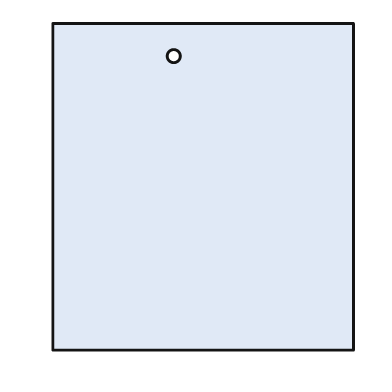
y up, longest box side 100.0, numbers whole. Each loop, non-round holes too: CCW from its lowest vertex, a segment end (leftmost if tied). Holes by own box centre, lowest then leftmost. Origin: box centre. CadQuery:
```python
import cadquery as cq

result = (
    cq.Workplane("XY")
    .moveTo(-46.0, -50.0)
    .lineTo(46.0, -50.0)
    .lineTo(46.0, 50.0)
    .lineTo(-46.0, 50.0)
    .close()
    .moveTo(-9.0, 40.0)
    .circle(2.0)
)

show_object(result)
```